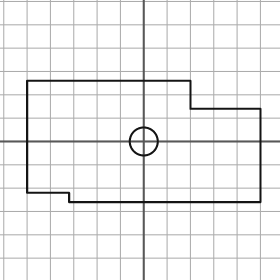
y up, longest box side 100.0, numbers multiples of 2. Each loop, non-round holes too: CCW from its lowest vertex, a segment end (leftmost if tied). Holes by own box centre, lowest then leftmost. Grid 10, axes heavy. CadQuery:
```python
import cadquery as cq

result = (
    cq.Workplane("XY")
    .moveTo(-32.0, -26.0)
    .lineTo(50.0, -26.0)
    .lineTo(50.0, 14.0)
    .lineTo(20.0, 14.0)
    .lineTo(20.0, 26.0)
    .lineTo(-50.0, 26.0)
    .lineTo(-50.0, -22.0)
    .lineTo(-32.0, -22.0)
    .close()
    .moveTo(0.0, 0.0)
    .circle(6.0)
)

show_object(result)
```